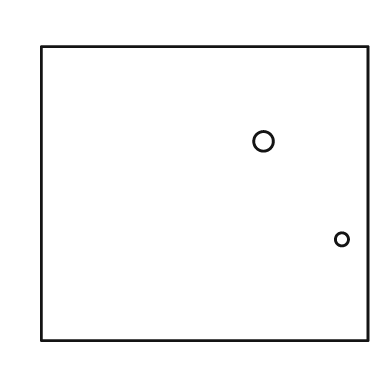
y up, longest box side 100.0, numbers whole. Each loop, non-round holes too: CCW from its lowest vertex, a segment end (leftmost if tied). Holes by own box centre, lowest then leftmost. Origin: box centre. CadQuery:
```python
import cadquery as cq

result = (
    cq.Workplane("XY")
    .moveTo(-50.0, -45.0)
    .lineTo(50.0, -45.0)
    .lineTo(50.0, 45.0)
    .lineTo(-50.0, 45.0)
    .close()
    .moveTo(42.0, -14.0)
    .circle(2.0)
    .moveTo(18.0, 16.0)
    .circle(3.0)
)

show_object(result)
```